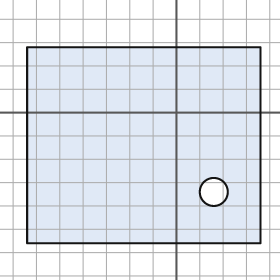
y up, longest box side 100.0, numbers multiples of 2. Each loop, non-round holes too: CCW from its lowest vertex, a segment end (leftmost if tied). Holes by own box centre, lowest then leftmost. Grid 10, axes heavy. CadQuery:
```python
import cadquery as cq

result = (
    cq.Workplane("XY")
    .moveTo(-64.0, -56.0)
    .lineTo(36.0, -56.0)
    .lineTo(36.0, 28.0)
    .lineTo(-64.0, 28.0)
    .close()
    .moveTo(16.0, -34.0)
    .circle(6.0)
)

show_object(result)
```